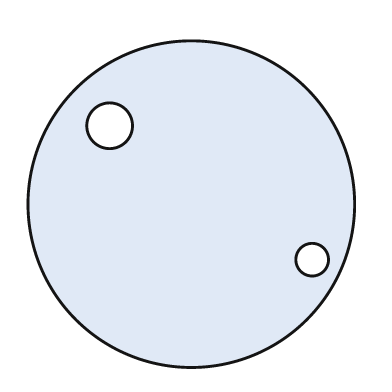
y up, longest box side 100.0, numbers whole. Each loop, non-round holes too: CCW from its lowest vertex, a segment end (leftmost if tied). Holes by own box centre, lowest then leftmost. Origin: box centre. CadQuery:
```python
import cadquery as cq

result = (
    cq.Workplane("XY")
    .moveTo(0.0, 0.0)
    .circle(50.0)
    .moveTo(37.0, -17.0)
    .circle(5.0)
    .moveTo(-25.0, 24.0)
    .circle(7.0)
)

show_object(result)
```